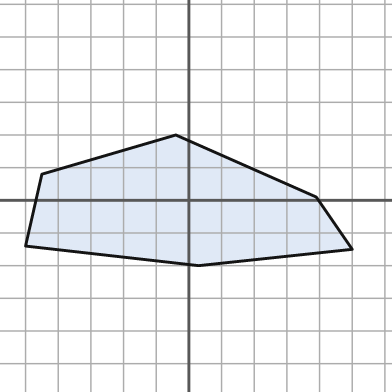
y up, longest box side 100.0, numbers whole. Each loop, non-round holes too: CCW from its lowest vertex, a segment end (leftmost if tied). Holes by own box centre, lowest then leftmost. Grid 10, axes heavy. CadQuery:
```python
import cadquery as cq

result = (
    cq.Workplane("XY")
    .moveTo(3.0, -20.0)
    .lineTo(50.0, -15.0)
    .lineTo(39.0, 1.0)
    .lineTo(-4.0, 20.0)
    .lineTo(-45.0, 8.0)
    .lineTo(-50.0, -14.0)
    .close()
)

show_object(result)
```